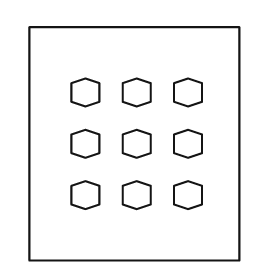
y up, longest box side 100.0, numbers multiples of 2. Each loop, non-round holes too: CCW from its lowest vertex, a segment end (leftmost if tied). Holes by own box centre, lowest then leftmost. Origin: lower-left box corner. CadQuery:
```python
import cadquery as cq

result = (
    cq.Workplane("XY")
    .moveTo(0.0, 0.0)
    .lineTo(90.0, 0.0)
    .lineTo(90.0, 100.0)
    .lineTo(0.0, 100.0)
    .close()
    .moveTo(24.0, 22.0)
    .lineTo(30.0, 24.0)
    .lineTo(30.0, 32.0)
    .lineTo(24.0, 34.0)
    .lineTo(18.0, 32.0)
    .lineTo(18.0, 24.0)
    .close()
    .moveTo(46.0, 22.0)
    .lineTo(52.0, 24.0)
    .lineTo(52.0, 32.0)
    .lineTo(46.0, 34.0)
    .lineTo(40.0, 32.0)
    .lineTo(40.0, 24.0)
    .close()
    .moveTo(68.0, 22.0)
    .lineTo(74.0, 24.0)
    .lineTo(74.0, 32.0)
    .lineTo(68.0, 34.0)
    .lineTo(62.0, 32.0)
    .lineTo(62.0, 24.0)
    .close()
    .moveTo(24.0, 44.0)
    .lineTo(30.0, 46.0)
    .lineTo(30.0, 54.0)
    .lineTo(24.0, 56.0)
    .lineTo(18.0, 54.0)
    .lineTo(18.0, 46.0)
    .close()
    .moveTo(46.0, 44.0)
    .lineTo(52.0, 46.0)
    .lineTo(52.0, 54.0)
    .lineTo(46.0, 56.0)
    .lineTo(40.0, 54.0)
    .lineTo(40.0, 46.0)
    .close()
    .moveTo(68.0, 44.0)
    .lineTo(74.0, 46.0)
    .lineTo(74.0, 54.0)
    .lineTo(68.0, 56.0)
    .lineTo(62.0, 54.0)
    .lineTo(62.0, 46.0)
    .close()
    .moveTo(24.0, 66.0)
    .lineTo(30.0, 68.0)
    .lineTo(30.0, 76.0)
    .lineTo(24.0, 78.0)
    .lineTo(18.0, 76.0)
    .lineTo(18.0, 68.0)
    .close()
    .moveTo(46.0, 66.0)
    .lineTo(52.0, 68.0)
    .lineTo(52.0, 76.0)
    .lineTo(46.0, 78.0)
    .lineTo(40.0, 76.0)
    .lineTo(40.0, 68.0)
    .close()
    .moveTo(68.0, 66.0)
    .lineTo(74.0, 68.0)
    .lineTo(74.0, 76.0)
    .lineTo(68.0, 78.0)
    .lineTo(62.0, 76.0)
    .lineTo(62.0, 68.0)
    .close()
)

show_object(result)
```